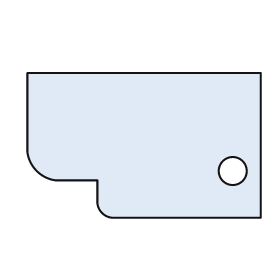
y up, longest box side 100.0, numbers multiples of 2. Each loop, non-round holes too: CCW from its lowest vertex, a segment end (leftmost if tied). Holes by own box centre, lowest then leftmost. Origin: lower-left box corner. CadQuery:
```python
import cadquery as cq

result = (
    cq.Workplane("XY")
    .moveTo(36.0, 0.0)
    .lineTo(100.0, 0.0)
    .lineTo(100.0, 62.0)
    .lineTo(0.0, 62.0)
    .lineTo(0.0, 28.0)
    .threePointArc((4.0, 20.0), (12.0, 16.0))
    .lineTo(30.0, 16.0)
    .lineTo(30.0, 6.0)
    .threePointArc((32.0, 2.0), (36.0, 0.0))
    .close()
    .moveTo(88.0, 20.0)
    .circle(6.0)
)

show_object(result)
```